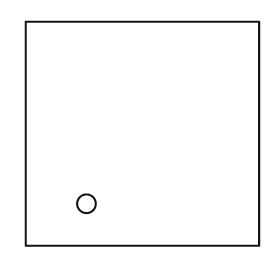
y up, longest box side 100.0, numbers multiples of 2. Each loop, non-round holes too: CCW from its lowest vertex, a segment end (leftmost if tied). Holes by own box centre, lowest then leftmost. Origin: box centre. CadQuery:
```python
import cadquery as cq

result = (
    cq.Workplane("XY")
    .moveTo(-50.0, -48.0)
    .lineTo(50.0, -48.0)
    .lineTo(50.0, 48.0)
    .lineTo(-50.0, 48.0)
    .close()
    .moveTo(-24.0, -30.0)
    .circle(4.0)
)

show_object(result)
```